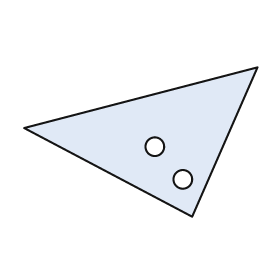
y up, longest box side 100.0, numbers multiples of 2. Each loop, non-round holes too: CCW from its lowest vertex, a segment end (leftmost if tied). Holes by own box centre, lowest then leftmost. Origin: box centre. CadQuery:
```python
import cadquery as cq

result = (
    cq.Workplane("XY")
    .moveTo(22.0, -32.0)
    .lineTo(50.0, 32.0)
    .lineTo(-50.0, 6.0)
    .close()
    .moveTo(18.0, -16.0)
    .circle(4.0)
    .moveTo(6.0, -2.0)
    .circle(4.0)
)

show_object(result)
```